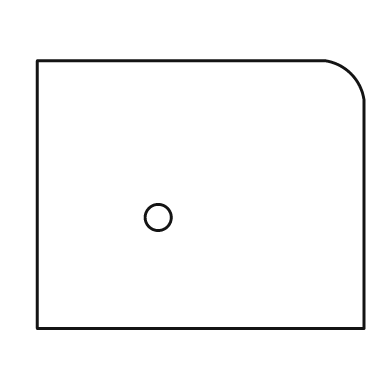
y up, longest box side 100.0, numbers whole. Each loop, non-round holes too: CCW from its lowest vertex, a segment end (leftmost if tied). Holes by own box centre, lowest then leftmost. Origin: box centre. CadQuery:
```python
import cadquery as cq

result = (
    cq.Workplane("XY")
    .moveTo(-50.0, -41.0)
    .lineTo(50.0, -41.0)
    .lineTo(50.0, 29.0)
    .threePointArc((46.0, 37.0), (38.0, 41.0))
    .lineTo(-50.0, 41.0)
    .close()
    .moveTo(-13.0, -7.0)
    .circle(4.0)
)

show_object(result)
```